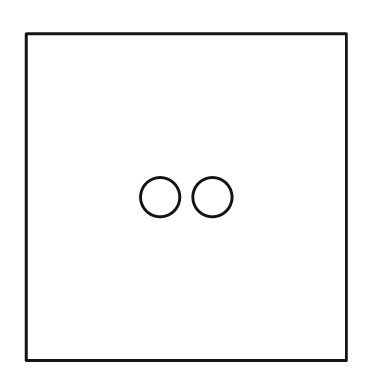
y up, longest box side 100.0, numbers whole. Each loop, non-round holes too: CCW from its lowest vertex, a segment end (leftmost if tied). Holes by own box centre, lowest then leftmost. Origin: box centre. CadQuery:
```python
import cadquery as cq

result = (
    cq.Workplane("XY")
    .moveTo(-49.0, -50.0)
    .lineTo(49.0, -50.0)
    .lineTo(49.0, 50.0)
    .lineTo(-49.0, 50.0)
    .close()
    .moveTo(-8.0, 0.0)
    .circle(6.0)
    .moveTo(8.0, 0.0)
    .circle(6.0)
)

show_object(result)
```